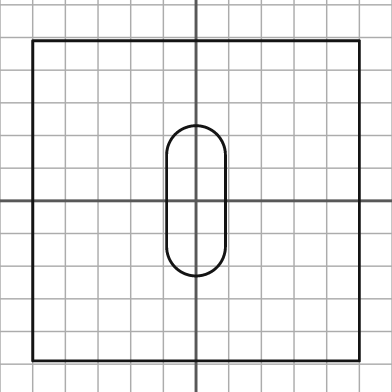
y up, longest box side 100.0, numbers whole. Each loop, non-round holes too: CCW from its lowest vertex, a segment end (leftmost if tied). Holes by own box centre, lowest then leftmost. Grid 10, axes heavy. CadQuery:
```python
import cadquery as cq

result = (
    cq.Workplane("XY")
    .moveTo(-50.0, -49.0)
    .lineTo(50.0, -49.0)
    .lineTo(50.0, 49.0)
    .lineTo(-50.0, 49.0)
    .close()
    .moveTo(-9.0, -14.0)
    .threePointArc((0.0, -23.0), (9.0, -14.0))
    .lineTo(9.0, 14.0)
    .threePointArc((0.0, 23.0), (-9.0, 14.0))
    .close()
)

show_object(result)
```